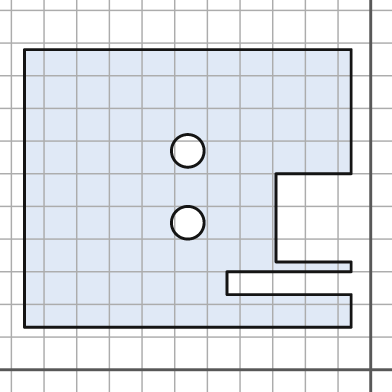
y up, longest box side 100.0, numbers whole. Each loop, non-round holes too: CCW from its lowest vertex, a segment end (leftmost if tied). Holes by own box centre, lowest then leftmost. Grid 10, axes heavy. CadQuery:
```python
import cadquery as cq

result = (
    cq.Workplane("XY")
    .moveTo(-106.0, 13.0)
    .lineTo(-6.0, 13.0)
    .lineTo(-6.0, 23.0)
    .lineTo(-44.0, 23.0)
    .lineTo(-44.0, 30.0)
    .lineTo(-6.0, 30.0)
    .lineTo(-6.0, 33.0)
    .lineTo(-29.0, 33.0)
    .lineTo(-29.0, 60.0)
    .lineTo(-6.0, 60.0)
    .lineTo(-6.0, 98.0)
    .lineTo(-106.0, 98.0)
    .close()
    .moveTo(-56.0, 45.0)
    .circle(5.0)
    .moveTo(-56.0, 67.0)
    .circle(5.0)
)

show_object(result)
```